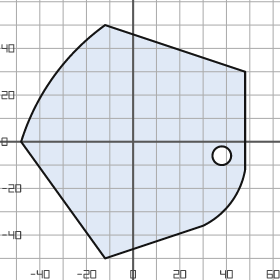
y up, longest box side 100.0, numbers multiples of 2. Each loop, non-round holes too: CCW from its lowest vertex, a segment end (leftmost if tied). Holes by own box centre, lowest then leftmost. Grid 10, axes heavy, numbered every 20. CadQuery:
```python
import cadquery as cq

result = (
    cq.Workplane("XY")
    .moveTo(-12.0, -50.0)
    .lineTo(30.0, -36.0)
    .threePointArc((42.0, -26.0), (48.0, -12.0))
    .lineTo(48.0, 30.0)
    .lineTo(-12.0, 50.0)
    .threePointArc((-34.0, 28.0), (-48.0, 0.0))
    .close()
    .moveTo(38.0, -6.0)
    .circle(4.0)
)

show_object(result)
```